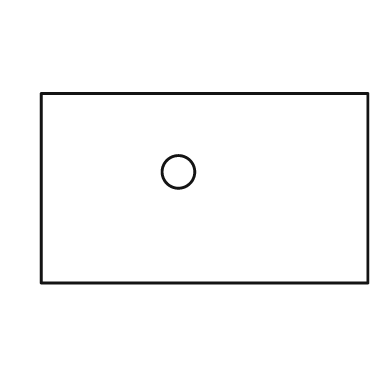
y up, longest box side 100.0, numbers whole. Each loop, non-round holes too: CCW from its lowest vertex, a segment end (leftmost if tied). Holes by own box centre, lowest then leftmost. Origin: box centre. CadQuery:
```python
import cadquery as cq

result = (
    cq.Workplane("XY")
    .moveTo(-50.0, -29.0)
    .lineTo(50.0, -29.0)
    .lineTo(50.0, 29.0)
    .lineTo(-50.0, 29.0)
    .close()
    .moveTo(-8.0, 5.0)
    .circle(5.0)
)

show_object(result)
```